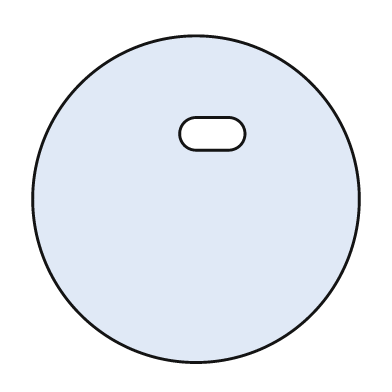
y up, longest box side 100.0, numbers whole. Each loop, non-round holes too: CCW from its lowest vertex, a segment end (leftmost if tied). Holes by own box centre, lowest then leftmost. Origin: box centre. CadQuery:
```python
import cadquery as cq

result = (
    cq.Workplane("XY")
    .moveTo(0.0, 0.0)
    .circle(50.0)
    .moveTo(0.0, 15.0)
    .lineTo(10.0, 15.0)
    .threePointArc((15.0, 20.0), (10.0, 25.0))
    .lineTo(0.0, 25.0)
    .threePointArc((-5.0, 20.0), (0.0, 15.0))
    .close()
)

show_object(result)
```